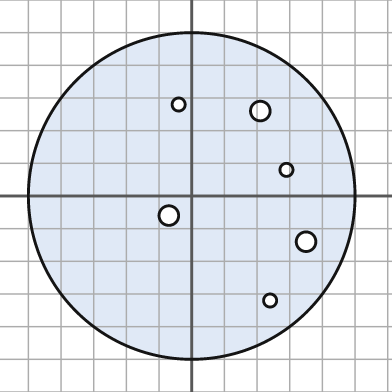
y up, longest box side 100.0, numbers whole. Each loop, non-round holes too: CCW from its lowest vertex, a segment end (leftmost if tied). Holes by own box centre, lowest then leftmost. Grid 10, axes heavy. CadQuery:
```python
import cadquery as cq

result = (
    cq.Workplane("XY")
    .moveTo(0.0, 0.0)
    .circle(50.0)
    .moveTo(24.0, -32.0)
    .circle(2.0)
    .moveTo(35.0, -14.0)
    .circle(3.0)
    .moveTo(-7.0, -6.0)
    .circle(3.0)
    .moveTo(29.0, 8.0)
    .circle(2.0)
    .moveTo(21.0, 26.0)
    .circle(3.0)
    .moveTo(-4.0, 28.0)
    .circle(2.0)
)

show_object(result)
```